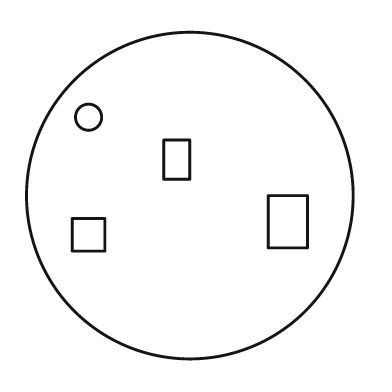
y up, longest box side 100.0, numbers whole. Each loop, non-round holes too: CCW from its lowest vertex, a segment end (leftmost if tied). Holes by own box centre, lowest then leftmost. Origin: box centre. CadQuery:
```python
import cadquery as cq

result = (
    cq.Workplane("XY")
    .moveTo(0.0, 0.0)
    .circle(50.0)
    .moveTo(-36.0, -17.0)
    .lineTo(-26.0, -17.0)
    .lineTo(-26.0, -7.0)
    .lineTo(-36.0, -7.0)
    .close()
    .moveTo(24.0, -16.0)
    .lineTo(36.0, -16.0)
    .lineTo(36.0, 0.0)
    .lineTo(24.0, 0.0)
    .close()
    .moveTo(-8.0, 5.0)
    .lineTo(0.0, 5.0)
    .lineTo(0.0, 17.0)
    .lineTo(-8.0, 17.0)
    .close()
    .moveTo(-31.0, 24.0)
    .circle(4.0)
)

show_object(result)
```